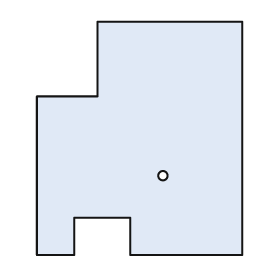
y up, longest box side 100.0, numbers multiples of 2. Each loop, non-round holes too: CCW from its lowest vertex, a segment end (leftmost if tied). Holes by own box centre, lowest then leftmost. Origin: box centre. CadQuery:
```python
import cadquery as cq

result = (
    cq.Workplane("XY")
    .moveTo(-44.0, -50.0)
    .lineTo(-28.0, -50.0)
    .lineTo(-28.0, -34.0)
    .lineTo(-4.0, -34.0)
    .lineTo(-4.0, -50.0)
    .lineTo(44.0, -50.0)
    .lineTo(44.0, 50.0)
    .lineTo(-18.0, 50.0)
    .lineTo(-18.0, 18.0)
    .lineTo(-44.0, 18.0)
    .close()
    .moveTo(10.0, -16.0)
    .circle(2.0)
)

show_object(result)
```